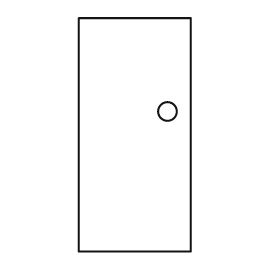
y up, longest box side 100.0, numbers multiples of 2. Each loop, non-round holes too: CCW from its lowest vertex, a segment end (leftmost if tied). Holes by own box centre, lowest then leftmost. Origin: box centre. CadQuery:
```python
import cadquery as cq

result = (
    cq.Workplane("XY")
    .moveTo(-24.0, -50.0)
    .lineTo(24.0, -50.0)
    .lineTo(24.0, 50.0)
    .lineTo(-24.0, 50.0)
    .close()
    .moveTo(14.0, 10.0)
    .circle(4.0)
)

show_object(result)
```